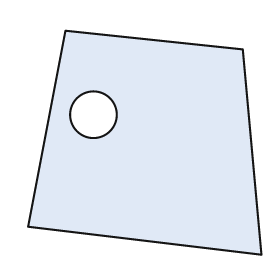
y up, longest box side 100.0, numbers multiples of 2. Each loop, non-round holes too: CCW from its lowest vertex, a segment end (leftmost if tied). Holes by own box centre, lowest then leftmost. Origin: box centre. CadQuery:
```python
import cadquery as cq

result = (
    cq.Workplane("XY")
    .moveTo(50.0, -48.0)
    .lineTo(42.0, 40.0)
    .lineTo(-34.0, 48.0)
    .lineTo(-50.0, -36.0)
    .close()
    .moveTo(-22.0, 12.0)
    .circle(10.0)
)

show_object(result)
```